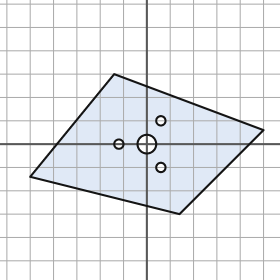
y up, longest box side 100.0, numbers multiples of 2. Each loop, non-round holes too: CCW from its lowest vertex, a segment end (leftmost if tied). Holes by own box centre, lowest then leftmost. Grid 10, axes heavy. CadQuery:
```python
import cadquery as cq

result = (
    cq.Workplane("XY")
    .moveTo(14.0, -30.0)
    .lineTo(50.0, 6.0)
    .lineTo(-14.0, 30.0)
    .lineTo(-50.0, -14.0)
    .close()
    .moveTo(6.0, -10.0)
    .circle(2.0)
    .moveTo(-12.0, 0.0)
    .circle(2.0)
    .moveTo(0.0, 0.0)
    .circle(4.0)
    .moveTo(6.0, 10.0)
    .circle(2.0)
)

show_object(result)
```